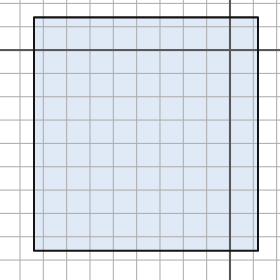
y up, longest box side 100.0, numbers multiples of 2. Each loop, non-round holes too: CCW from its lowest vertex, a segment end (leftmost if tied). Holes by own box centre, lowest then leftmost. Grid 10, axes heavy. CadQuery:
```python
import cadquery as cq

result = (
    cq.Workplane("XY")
    .moveTo(-84.0, -86.0)
    .lineTo(12.0, -86.0)
    .lineTo(12.0, 14.0)
    .lineTo(-84.0, 14.0)
    .close()
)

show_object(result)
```